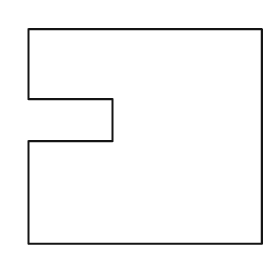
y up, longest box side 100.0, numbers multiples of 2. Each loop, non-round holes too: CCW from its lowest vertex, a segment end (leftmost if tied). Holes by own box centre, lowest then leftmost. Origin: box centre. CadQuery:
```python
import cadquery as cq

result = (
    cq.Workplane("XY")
    .moveTo(-50.0, -46.0)
    .lineTo(50.0, -46.0)
    .lineTo(50.0, 46.0)
    .lineTo(-50.0, 46.0)
    .lineTo(-50.0, 16.0)
    .lineTo(-14.0, 16.0)
    .lineTo(-14.0, -2.0)
    .lineTo(-50.0, -2.0)
    .close()
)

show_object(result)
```